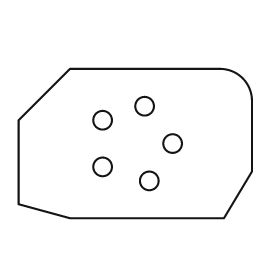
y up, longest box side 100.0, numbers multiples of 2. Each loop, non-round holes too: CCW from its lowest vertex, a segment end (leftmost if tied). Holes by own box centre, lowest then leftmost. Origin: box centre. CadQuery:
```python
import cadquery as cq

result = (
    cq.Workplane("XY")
    .moveTo(-28.0, -32.0)
    .lineTo(38.0, -32.0)
    .lineTo(50.0, -12.0)
    .lineTo(50.0, 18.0)
    .threePointArc((46.0, 28.0), (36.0, 32.0))
    .lineTo(-28.0, 32.0)
    .lineTo(-50.0, 10.0)
    .lineTo(-50.0, -26.0)
    .close()
    .moveTo(6.0, -16.0)
    .circle(4.0)
    .moveTo(-14.0, -10.0)
    .circle(4.0)
    .moveTo(16.0, 0.0)
    .circle(4.0)
    .moveTo(-14.0, 10.0)
    .circle(4.0)
    .moveTo(4.0, 16.0)
    .circle(4.0)
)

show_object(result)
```